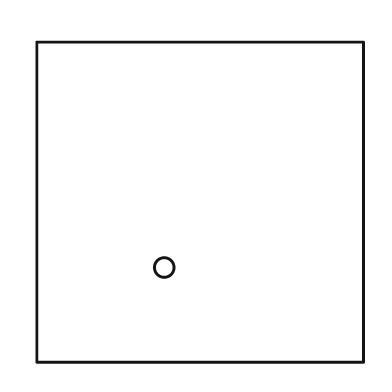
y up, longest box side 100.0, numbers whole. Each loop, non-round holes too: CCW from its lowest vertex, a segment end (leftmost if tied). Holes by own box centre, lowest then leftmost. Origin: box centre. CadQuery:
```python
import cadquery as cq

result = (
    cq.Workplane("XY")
    .moveTo(-50.0, -49.0)
    .lineTo(50.0, -49.0)
    .lineTo(50.0, 49.0)
    .lineTo(-50.0, 49.0)
    .close()
    .moveTo(-11.0, -20.0)
    .circle(3.0)
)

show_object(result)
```